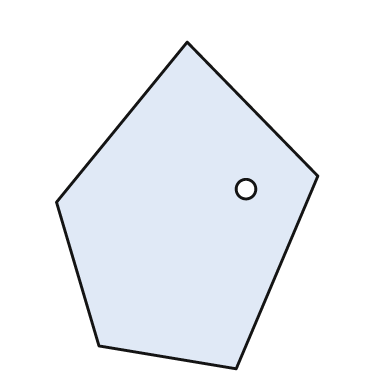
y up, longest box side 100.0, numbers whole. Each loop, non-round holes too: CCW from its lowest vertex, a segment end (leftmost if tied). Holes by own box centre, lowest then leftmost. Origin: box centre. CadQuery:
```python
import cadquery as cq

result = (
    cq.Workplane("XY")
    .moveTo(15.0, -50.0)
    .lineTo(40.0, 9.0)
    .lineTo(0.0, 50.0)
    .lineTo(-40.0, 1.0)
    .lineTo(-27.0, -43.0)
    .close()
    .moveTo(18.0, 5.0)
    .circle(3.0)
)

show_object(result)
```